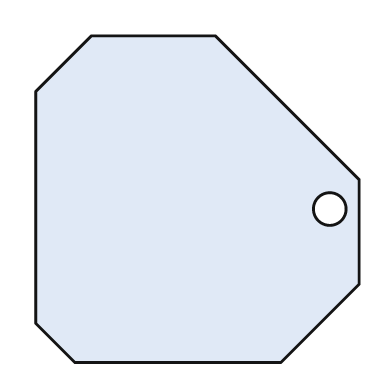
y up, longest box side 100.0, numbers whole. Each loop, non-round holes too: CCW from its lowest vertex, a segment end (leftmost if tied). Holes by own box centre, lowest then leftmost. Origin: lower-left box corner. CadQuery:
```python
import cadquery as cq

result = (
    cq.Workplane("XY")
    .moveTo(12.0, 0.0)
    .lineTo(75.0, 0.0)
    .lineTo(99.0, 24.0)
    .lineTo(99.0, 56.0)
    .lineTo(55.0, 100.0)
    .lineTo(17.0, 100.0)
    .lineTo(0.0, 83.0)
    .lineTo(0.0, 12.0)
    .close()
    .moveTo(90.0, 47.0)
    .circle(5.0)
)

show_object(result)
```